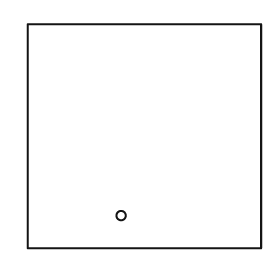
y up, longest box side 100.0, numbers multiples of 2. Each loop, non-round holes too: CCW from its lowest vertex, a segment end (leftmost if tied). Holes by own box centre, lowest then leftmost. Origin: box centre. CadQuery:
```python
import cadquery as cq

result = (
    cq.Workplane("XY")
    .moveTo(-50.0, -48.0)
    .lineTo(50.0, -48.0)
    .lineTo(50.0, 48.0)
    .lineTo(-50.0, 48.0)
    .close()
    .moveTo(-10.0, -34.0)
    .circle(2.0)
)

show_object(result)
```